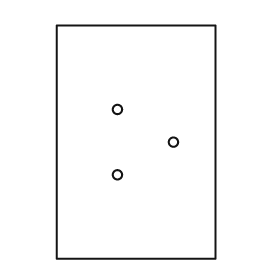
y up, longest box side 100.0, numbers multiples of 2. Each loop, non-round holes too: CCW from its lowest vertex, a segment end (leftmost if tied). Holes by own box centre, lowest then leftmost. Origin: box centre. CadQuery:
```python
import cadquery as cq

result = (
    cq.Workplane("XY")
    .moveTo(-34.0, -50.0)
    .lineTo(34.0, -50.0)
    .lineTo(34.0, 50.0)
    .lineTo(-34.0, 50.0)
    .close()
    .moveTo(-8.0, -14.0)
    .circle(2.0)
    .moveTo(16.0, 0.0)
    .circle(2.0)
    .moveTo(-8.0, 14.0)
    .circle(2.0)
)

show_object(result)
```